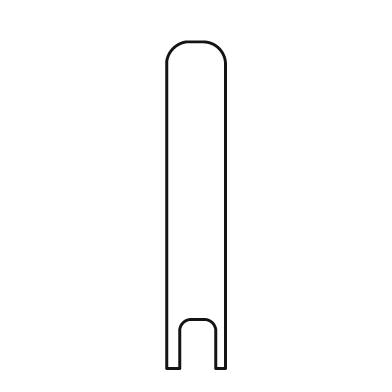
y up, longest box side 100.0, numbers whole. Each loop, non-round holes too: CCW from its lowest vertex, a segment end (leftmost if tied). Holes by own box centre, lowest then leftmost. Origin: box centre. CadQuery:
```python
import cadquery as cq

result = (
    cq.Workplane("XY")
    .moveTo(-9.0, -50.0)
    .lineTo(-5.0, -50.0)
    .lineTo(-5.0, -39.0)
    .threePointArc((-4.0, -36.0), (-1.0, -35.0))
    .lineTo(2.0, -35.0)
    .threePointArc((5.0, -36.0), (6.0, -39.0))
    .lineTo(6.0, -50.0)
    .lineTo(9.0, -50.0)
    .lineTo(9.0, 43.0)
    .threePointArc((7.0, 48.0), (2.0, 50.0))
    .lineTo(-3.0, 50.0)
    .threePointArc((-7.0, 48.0), (-9.0, 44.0))
    .close()
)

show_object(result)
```